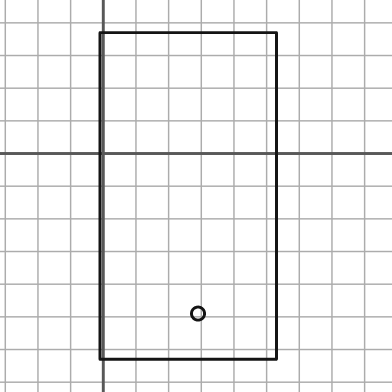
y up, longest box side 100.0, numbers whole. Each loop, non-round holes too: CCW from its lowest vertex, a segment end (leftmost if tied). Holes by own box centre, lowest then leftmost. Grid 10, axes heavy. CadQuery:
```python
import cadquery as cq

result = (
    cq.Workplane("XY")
    .moveTo(-1.0, -63.0)
    .lineTo(53.0, -63.0)
    .lineTo(53.0, 37.0)
    .lineTo(-1.0, 37.0)
    .close()
    .moveTo(29.0, -49.0)
    .circle(2.0)
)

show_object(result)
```